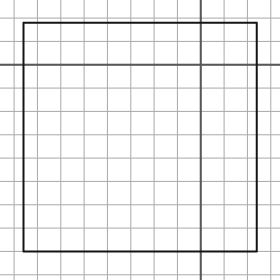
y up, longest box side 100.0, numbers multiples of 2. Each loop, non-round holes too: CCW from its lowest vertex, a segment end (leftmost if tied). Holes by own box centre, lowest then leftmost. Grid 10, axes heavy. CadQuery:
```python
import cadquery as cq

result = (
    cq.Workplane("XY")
    .moveTo(-76.0, -80.0)
    .lineTo(24.0, -80.0)
    .lineTo(24.0, 18.0)
    .lineTo(-76.0, 18.0)
    .close()
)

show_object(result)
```